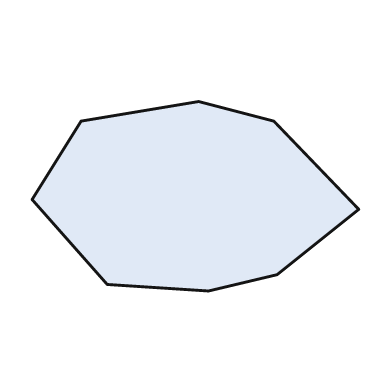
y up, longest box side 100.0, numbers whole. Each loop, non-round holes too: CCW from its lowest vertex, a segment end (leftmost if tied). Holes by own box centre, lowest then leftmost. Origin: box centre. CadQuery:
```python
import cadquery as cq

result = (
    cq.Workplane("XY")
    .moveTo(4.0, -29.0)
    .lineTo(25.0, -24.0)
    .lineTo(50.0, -4.0)
    .lineTo(24.0, 23.0)
    .lineTo(1.0, 29.0)
    .lineTo(-35.0, 23.0)
    .lineTo(-50.0, -1.0)
    .lineTo(-27.0, -27.0)
    .close()
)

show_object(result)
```